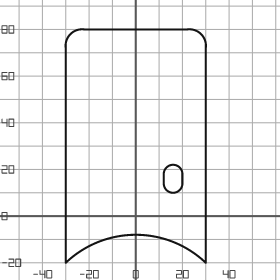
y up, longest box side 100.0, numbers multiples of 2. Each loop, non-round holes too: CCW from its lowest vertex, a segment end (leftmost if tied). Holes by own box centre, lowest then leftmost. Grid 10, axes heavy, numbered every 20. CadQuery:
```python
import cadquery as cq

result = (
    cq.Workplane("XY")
    .moveTo(-30.0, -20.0)
    .threePointArc((0.0, -8.0), (30.0, -20.0))
    .lineTo(30.0, 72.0)
    .threePointArc((28.0, 78.0), (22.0, 80.0))
    .lineTo(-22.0, 80.0)
    .threePointArc((-28.0, 78.0), (-30.0, 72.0))
    .close()
    .moveTo(12.0, 14.0)
    .threePointArc((16.0, 10.0), (20.0, 14.0))
    .lineTo(20.0, 18.0)
    .threePointArc((16.0, 22.0), (12.0, 18.0))
    .close()
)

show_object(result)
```